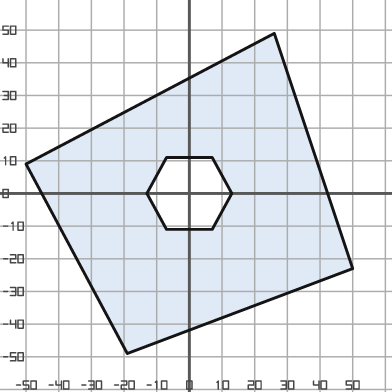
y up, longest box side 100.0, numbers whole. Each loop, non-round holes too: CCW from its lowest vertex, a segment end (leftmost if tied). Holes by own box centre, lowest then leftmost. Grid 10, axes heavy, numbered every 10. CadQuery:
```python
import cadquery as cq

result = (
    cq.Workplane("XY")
    .moveTo(-19.0, -49.0)
    .lineTo(50.0, -23.0)
    .lineTo(26.0, 49.0)
    .lineTo(-50.0, 9.0)
    .close()
    .moveTo(-7.0, -11.0)
    .lineTo(7.0, -11.0)
    .lineTo(13.0, 0.0)
    .lineTo(7.0, 11.0)
    .lineTo(-7.0, 11.0)
    .lineTo(-13.0, 0.0)
    .close()
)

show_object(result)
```